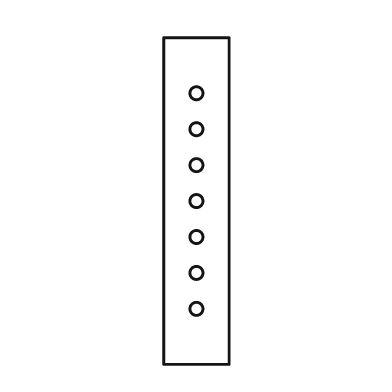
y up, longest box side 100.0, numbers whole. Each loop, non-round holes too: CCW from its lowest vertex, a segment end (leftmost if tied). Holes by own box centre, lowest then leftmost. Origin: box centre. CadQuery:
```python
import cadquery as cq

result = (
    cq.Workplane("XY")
    .moveTo(-10.0, -50.0)
    .lineTo(10.0, -50.0)
    .lineTo(10.0, 50.0)
    .lineTo(-10.0, 50.0)
    .close()
    .moveTo(0.0, -33.0)
    .circle(2.0)
    .moveTo(0.0, -22.0)
    .circle(2.0)
    .moveTo(0.0, -11.0)
    .circle(2.0)
    .moveTo(0.0, 0.0)
    .circle(2.0)
    .moveTo(0.0, 11.0)
    .circle(2.0)
    .moveTo(0.0, 22.0)
    .circle(2.0)
    .moveTo(0.0, 33.0)
    .circle(2.0)
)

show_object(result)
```